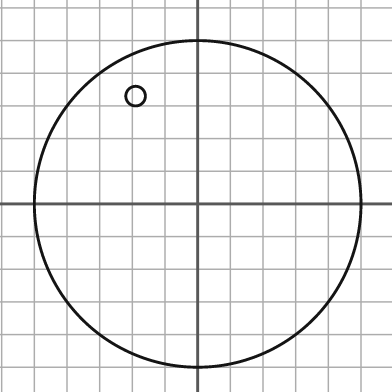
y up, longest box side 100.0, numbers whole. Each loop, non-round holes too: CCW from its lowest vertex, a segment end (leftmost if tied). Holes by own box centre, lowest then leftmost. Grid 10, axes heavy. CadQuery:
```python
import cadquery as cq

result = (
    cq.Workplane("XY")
    .moveTo(0.0, 0.0)
    .circle(50.0)
    .moveTo(-19.0, 33.0)
    .circle(3.0)
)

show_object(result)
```